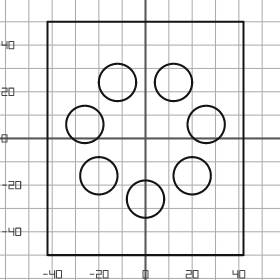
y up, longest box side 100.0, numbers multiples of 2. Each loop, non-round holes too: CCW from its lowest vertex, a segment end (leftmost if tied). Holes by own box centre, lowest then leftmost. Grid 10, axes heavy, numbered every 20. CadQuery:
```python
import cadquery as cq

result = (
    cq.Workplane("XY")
    .moveTo(-42.0, -50.0)
    .lineTo(42.0, -50.0)
    .lineTo(42.0, 50.0)
    .lineTo(-42.0, 50.0)
    .close()
    .moveTo(0.0, -26.0)
    .circle(8.0)
    .moveTo(-20.0, -16.0)
    .circle(8.0)
    .moveTo(20.0, -16.0)
    .circle(8.0)
    .moveTo(-26.0, 6.0)
    .circle(8.0)
    .moveTo(26.0, 6.0)
    .circle(8.0)
    .moveTo(-12.0, 24.0)
    .circle(8.0)
    .moveTo(12.0, 24.0)
    .circle(8.0)
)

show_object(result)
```